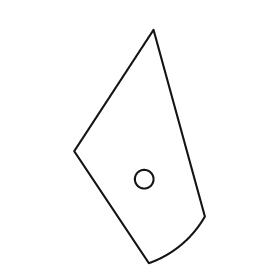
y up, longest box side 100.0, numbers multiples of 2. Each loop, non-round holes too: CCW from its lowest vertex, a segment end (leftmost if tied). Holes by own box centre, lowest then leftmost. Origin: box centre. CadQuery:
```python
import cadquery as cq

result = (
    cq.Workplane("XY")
    .moveTo(4.0, -50.0)
    .threePointArc((18.0, -42.0), (28.0, -30.0))
    .lineTo(6.0, 50.0)
    .lineTo(-28.0, -2.0)
    .close()
    .moveTo(2.0, -14.0)
    .circle(4.0)
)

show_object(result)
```